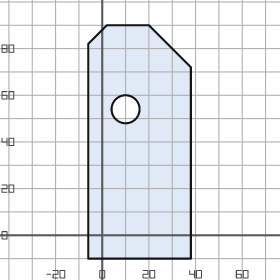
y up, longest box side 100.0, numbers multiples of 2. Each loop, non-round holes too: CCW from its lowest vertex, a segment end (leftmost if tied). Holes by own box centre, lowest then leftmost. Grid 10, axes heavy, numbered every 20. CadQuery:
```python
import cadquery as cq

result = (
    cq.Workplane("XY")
    .moveTo(-6.0, -10.0)
    .lineTo(38.0, -10.0)
    .lineTo(38.0, 72.0)
    .lineTo(20.0, 90.0)
    .lineTo(2.0, 90.0)
    .lineTo(-6.0, 82.0)
    .close()
    .moveTo(10.0, 54.0)
    .circle(6.0)
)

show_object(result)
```